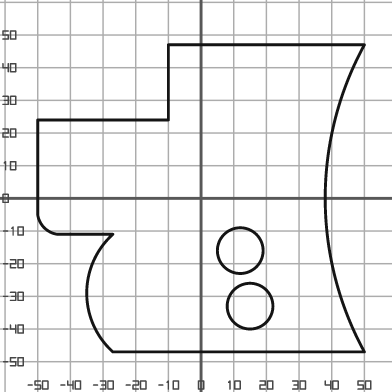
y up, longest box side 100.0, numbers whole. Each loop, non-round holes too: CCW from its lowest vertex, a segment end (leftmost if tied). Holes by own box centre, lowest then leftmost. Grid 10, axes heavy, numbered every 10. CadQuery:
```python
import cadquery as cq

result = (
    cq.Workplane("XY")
    .moveTo(-27.0, -47.0)
    .lineTo(50.0, -47.0)
    .threePointArc((38.0, 0.0), (50.0, 47.0))
    .lineTo(-10.0, 47.0)
    .lineTo(-10.0, 24.0)
    .lineTo(-50.0, 24.0)
    .lineTo(-50.0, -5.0)
    .threePointArc((-48.0, -9.0), (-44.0, -11.0))
    .lineTo(-27.0, -11.0)
    .threePointArc((-35.0, -29.0), (-27.0, -47.0))
    .close()
    .moveTo(15.0, -33.0)
    .circle(7.0)
    .moveTo(12.0, -16.0)
    .circle(7.0)
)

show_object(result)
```